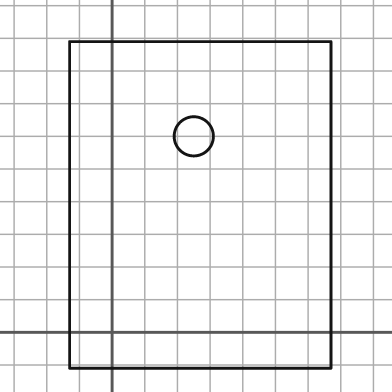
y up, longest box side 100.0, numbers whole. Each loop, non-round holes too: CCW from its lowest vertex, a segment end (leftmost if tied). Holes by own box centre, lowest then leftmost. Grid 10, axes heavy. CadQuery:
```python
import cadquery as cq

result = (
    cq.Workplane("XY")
    .moveTo(-13.0, -11.0)
    .lineTo(67.0, -11.0)
    .lineTo(67.0, 89.0)
    .lineTo(-13.0, 89.0)
    .close()
    .moveTo(25.0, 60.0)
    .circle(6.0)
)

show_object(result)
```